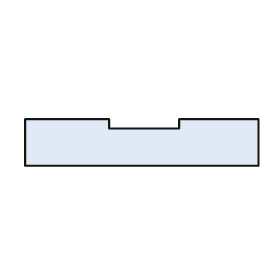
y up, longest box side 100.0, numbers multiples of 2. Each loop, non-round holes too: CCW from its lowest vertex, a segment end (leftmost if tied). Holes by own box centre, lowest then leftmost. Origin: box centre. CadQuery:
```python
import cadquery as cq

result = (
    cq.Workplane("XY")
    .moveTo(-50.0, -10.0)
    .lineTo(50.0, -10.0)
    .lineTo(50.0, 10.0)
    .lineTo(16.0, 10.0)
    .lineTo(16.0, 6.0)
    .lineTo(-14.0, 6.0)
    .lineTo(-14.0, 10.0)
    .lineTo(-50.0, 10.0)
    .close()
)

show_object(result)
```